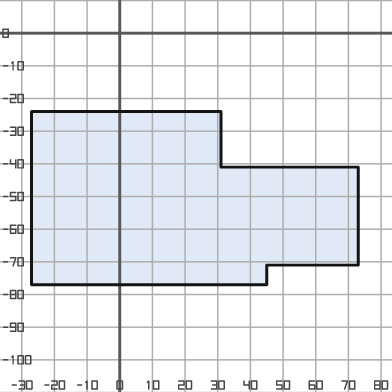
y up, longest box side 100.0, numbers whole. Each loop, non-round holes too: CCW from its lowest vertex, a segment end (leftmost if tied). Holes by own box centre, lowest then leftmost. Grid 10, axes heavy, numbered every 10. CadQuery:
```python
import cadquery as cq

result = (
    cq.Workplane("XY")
    .moveTo(-27.0, -77.0)
    .lineTo(45.0, -77.0)
    .lineTo(45.0, -71.0)
    .lineTo(73.0, -71.0)
    .lineTo(73.0, -41.0)
    .lineTo(31.0, -41.0)
    .lineTo(31.0, -24.0)
    .lineTo(-27.0, -24.0)
    .close()
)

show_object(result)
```